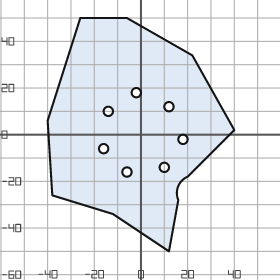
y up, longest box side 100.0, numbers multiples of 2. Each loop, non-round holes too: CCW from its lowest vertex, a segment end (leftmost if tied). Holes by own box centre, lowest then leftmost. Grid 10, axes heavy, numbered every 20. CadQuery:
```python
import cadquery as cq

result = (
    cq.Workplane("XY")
    .moveTo(12.0, -50.0)
    .lineTo(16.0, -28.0)
    .threePointArc((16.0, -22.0), (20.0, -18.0))
    .lineTo(40.0, 2.0)
    .lineTo(22.0, 34.0)
    .lineTo(-6.0, 50.0)
    .lineTo(-26.0, 50.0)
    .lineTo(-40.0, 6.0)
    .lineTo(-38.0, -26.0)
    .lineTo(-12.0, -34.0)
    .close()
    .moveTo(-6.0, -16.0)
    .circle(2.0)
    .moveTo(10.0, -14.0)
    .circle(2.0)
    .moveTo(-16.0, -6.0)
    .circle(2.0)
    .moveTo(18.0, -2.0)
    .circle(2.0)
    .moveTo(-14.0, 10.0)
    .circle(2.0)
    .moveTo(12.0, 12.0)
    .circle(2.0)
    .moveTo(-2.0, 18.0)
    .circle(2.0)
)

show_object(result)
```